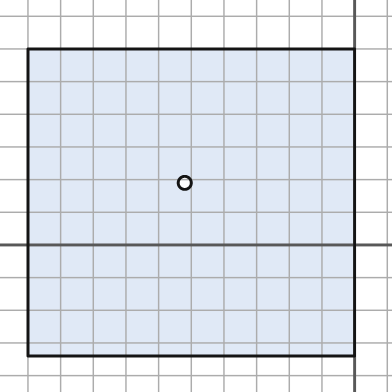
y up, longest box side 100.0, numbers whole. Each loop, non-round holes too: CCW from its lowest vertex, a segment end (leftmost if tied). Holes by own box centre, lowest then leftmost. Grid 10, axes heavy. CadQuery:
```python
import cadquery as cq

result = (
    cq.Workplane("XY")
    .moveTo(-100.0, -34.0)
    .lineTo(0.0, -34.0)
    .lineTo(0.0, 60.0)
    .lineTo(-100.0, 60.0)
    .close()
    .moveTo(-52.0, 19.0)
    .circle(2.0)
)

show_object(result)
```